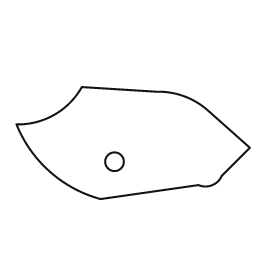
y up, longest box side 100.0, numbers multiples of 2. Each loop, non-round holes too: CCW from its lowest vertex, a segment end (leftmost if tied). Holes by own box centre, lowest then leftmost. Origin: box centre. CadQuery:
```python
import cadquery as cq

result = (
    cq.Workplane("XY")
    .moveTo(-14.0, -24.0)
    .lineTo(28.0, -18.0)
    .threePointArc((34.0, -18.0), (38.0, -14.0))
    .lineTo(50.0, -2.0)
    .lineTo(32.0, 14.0)
    .threePointArc((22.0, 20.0), (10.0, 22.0))
    .lineTo(-22.0, 24.0)
    .threePointArc((-34.0, 12.0), (-50.0, 8.0))
    .threePointArc((-36.0, -12.0), (-14.0, -24.0))
    .close()
    .moveTo(-8.0, -8.0)
    .circle(4.0)
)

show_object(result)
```